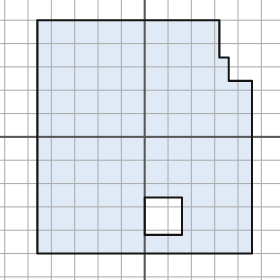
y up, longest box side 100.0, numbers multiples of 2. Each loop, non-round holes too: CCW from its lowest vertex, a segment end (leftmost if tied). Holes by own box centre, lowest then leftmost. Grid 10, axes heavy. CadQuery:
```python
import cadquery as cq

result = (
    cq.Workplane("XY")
    .moveTo(-46.0, -50.0)
    .lineTo(46.0, -50.0)
    .lineTo(46.0, 24.0)
    .lineTo(36.0, 24.0)
    .lineTo(36.0, 34.0)
    .lineTo(32.0, 34.0)
    .lineTo(32.0, 50.0)
    .lineTo(-46.0, 50.0)
    .close()
    .moveTo(0.0, -42.0)
    .lineTo(16.0, -42.0)
    .lineTo(16.0, -26.0)
    .lineTo(0.0, -26.0)
    .close()
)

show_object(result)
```